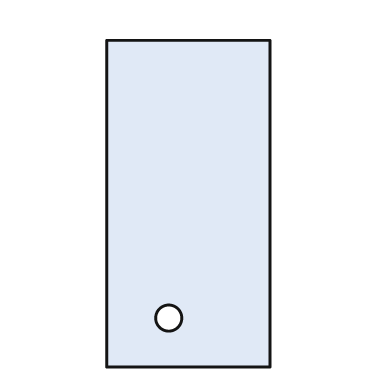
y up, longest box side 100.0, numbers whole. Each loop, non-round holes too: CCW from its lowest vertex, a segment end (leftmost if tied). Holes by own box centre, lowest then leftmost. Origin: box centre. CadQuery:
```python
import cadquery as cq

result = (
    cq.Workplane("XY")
    .moveTo(-25.0, -50.0)
    .lineTo(25.0, -50.0)
    .lineTo(25.0, 50.0)
    .lineTo(-25.0, 50.0)
    .close()
    .moveTo(-6.0, -35.0)
    .circle(4.0)
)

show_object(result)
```